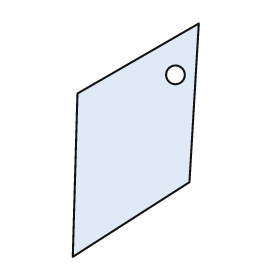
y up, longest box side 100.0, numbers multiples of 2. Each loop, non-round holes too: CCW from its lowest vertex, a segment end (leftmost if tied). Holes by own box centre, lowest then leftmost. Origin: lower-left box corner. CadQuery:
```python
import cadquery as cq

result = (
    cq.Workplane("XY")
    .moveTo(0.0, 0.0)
    .lineTo(50.0, 32.0)
    .lineTo(54.0, 100.0)
    .lineTo(2.0, 70.0)
    .close()
    .moveTo(44.0, 78.0)
    .circle(4.0)
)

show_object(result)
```